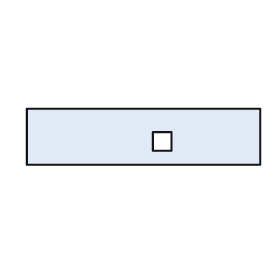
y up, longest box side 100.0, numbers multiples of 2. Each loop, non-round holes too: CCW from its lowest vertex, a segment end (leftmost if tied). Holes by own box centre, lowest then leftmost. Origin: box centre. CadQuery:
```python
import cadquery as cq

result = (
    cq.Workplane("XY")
    .moveTo(-50.0, -12.0)
    .lineTo(50.0, -12.0)
    .lineTo(50.0, 12.0)
    .lineTo(-50.0, 12.0)
    .close()
    .moveTo(4.0, -6.0)
    .lineTo(12.0, -6.0)
    .lineTo(12.0, 2.0)
    .lineTo(4.0, 2.0)
    .close()
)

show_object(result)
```